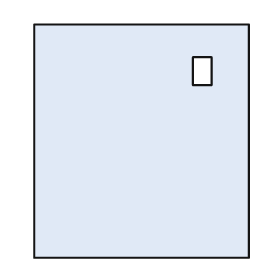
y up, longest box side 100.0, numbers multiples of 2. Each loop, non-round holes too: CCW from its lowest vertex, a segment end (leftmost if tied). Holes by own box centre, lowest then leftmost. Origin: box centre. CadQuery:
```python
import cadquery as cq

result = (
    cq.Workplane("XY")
    .moveTo(-46.0, -50.0)
    .lineTo(46.0, -50.0)
    .lineTo(46.0, 50.0)
    .lineTo(-46.0, 50.0)
    .close()
    .moveTo(22.0, 24.0)
    .lineTo(30.0, 24.0)
    .lineTo(30.0, 36.0)
    .lineTo(22.0, 36.0)
    .close()
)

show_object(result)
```